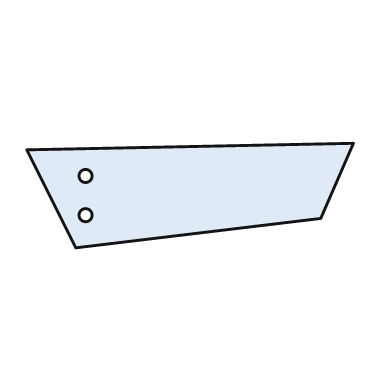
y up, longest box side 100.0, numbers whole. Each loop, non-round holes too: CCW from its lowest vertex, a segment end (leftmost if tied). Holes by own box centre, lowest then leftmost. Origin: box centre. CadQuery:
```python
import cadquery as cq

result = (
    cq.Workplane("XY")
    .moveTo(-35.0, -16.0)
    .lineTo(40.0, -7.0)
    .lineTo(50.0, 16.0)
    .lineTo(-50.0, 14.0)
    .close()
    .moveTo(-32.0, -6.0)
    .circle(2.0)
    .moveTo(-32.0, 6.0)
    .circle(2.0)
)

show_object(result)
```